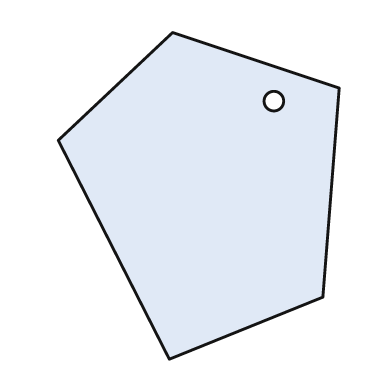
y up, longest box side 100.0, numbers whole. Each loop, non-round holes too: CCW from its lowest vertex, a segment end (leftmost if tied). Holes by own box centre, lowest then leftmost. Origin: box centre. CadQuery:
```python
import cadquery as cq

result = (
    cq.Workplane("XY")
    .moveTo(-9.0, -50.0)
    .lineTo(38.0, -31.0)
    .lineTo(43.0, 33.0)
    .lineTo(-8.0, 50.0)
    .lineTo(-43.0, 17.0)
    .close()
    .moveTo(23.0, 29.0)
    .circle(3.0)
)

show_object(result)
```